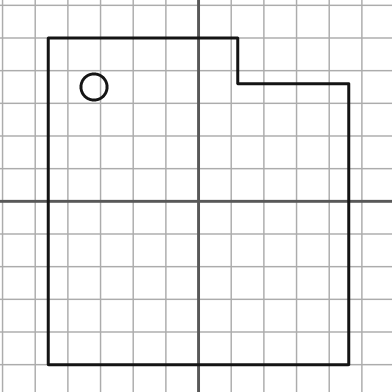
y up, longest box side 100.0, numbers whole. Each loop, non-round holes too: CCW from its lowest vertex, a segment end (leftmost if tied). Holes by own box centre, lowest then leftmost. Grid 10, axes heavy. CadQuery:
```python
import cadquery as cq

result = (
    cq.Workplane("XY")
    .moveTo(-46.0, -50.0)
    .lineTo(46.0, -50.0)
    .lineTo(46.0, 36.0)
    .lineTo(12.0, 36.0)
    .lineTo(12.0, 50.0)
    .lineTo(-46.0, 50.0)
    .close()
    .moveTo(-32.0, 35.0)
    .circle(4.0)
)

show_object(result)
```